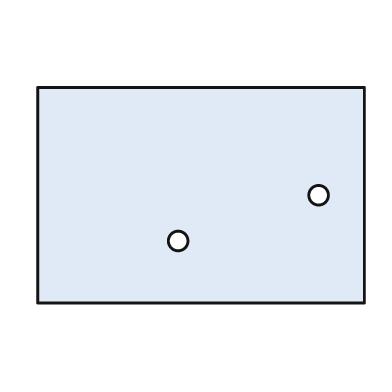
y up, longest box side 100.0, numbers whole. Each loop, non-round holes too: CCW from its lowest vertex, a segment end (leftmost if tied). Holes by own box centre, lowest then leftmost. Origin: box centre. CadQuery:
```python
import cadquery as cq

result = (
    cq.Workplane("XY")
    .moveTo(-50.0, -33.0)
    .lineTo(50.0, -33.0)
    .lineTo(50.0, 33.0)
    .lineTo(-50.0, 33.0)
    .close()
    .moveTo(-7.0, -14.0)
    .circle(3.0)
    .moveTo(36.0, 0.0)
    .circle(3.0)
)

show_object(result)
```